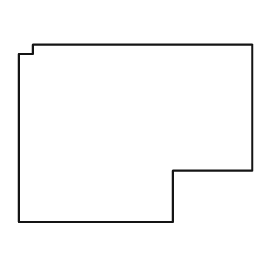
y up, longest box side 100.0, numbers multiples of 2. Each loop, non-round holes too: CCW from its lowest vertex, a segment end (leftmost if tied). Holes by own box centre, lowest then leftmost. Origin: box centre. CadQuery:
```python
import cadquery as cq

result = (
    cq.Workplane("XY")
    .moveTo(-50.0, -38.0)
    .lineTo(16.0, -38.0)
    .lineTo(16.0, -16.0)
    .lineTo(50.0, -16.0)
    .lineTo(50.0, 38.0)
    .lineTo(-44.0, 38.0)
    .lineTo(-44.0, 34.0)
    .lineTo(-50.0, 34.0)
    .close()
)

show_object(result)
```